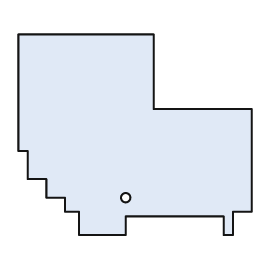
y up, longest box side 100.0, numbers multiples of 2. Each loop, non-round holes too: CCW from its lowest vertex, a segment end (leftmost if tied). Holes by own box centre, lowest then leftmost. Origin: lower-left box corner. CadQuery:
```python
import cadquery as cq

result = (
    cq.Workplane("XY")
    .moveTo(26.0, 0.0)
    .lineTo(46.0, 0.0)
    .lineTo(46.0, 8.0)
    .lineTo(88.0, 8.0)
    .lineTo(88.0, 0.0)
    .lineTo(92.0, 0.0)
    .lineTo(92.0, 10.0)
    .lineTo(100.0, 10.0)
    .lineTo(100.0, 54.0)
    .lineTo(58.0, 54.0)
    .lineTo(58.0, 86.0)
    .lineTo(0.0, 86.0)
    .lineTo(0.0, 36.0)
    .lineTo(4.0, 36.0)
    .lineTo(4.0, 24.0)
    .lineTo(12.0, 24.0)
    .lineTo(12.0, 16.0)
    .lineTo(20.0, 16.0)
    .lineTo(20.0, 10.0)
    .lineTo(26.0, 10.0)
    .close()
    .moveTo(46.0, 16.0)
    .circle(2.0)
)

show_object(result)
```